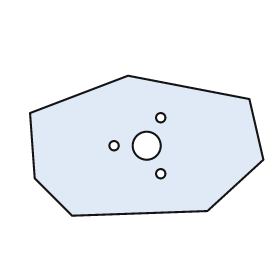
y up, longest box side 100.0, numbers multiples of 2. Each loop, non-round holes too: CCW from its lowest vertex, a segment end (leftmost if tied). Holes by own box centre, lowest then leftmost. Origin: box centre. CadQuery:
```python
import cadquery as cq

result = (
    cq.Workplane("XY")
    .moveTo(-32.0, -30.0)
    .lineTo(26.0, -28.0)
    .lineTo(50.0, -6.0)
    .lineTo(44.0, 20.0)
    .lineTo(-8.0, 30.0)
    .lineTo(-50.0, 14.0)
    .lineTo(-48.0, -14.0)
    .close()
    .moveTo(6.0, -12.0)
    .circle(2.0)
    .moveTo(-14.0, 0.0)
    .circle(2.0)
    .moveTo(0.0, 0.0)
    .circle(6.0)
    .moveTo(6.0, 12.0)
    .circle(2.0)
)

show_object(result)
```